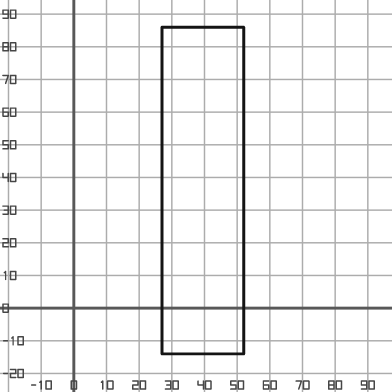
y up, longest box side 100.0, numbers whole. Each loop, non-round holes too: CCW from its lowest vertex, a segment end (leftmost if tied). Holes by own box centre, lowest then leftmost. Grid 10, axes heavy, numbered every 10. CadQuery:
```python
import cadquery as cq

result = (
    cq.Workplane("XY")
    .moveTo(27.0, -14.0)
    .lineTo(52.0, -14.0)
    .lineTo(52.0, 86.0)
    .lineTo(27.0, 86.0)
    .close()
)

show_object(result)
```